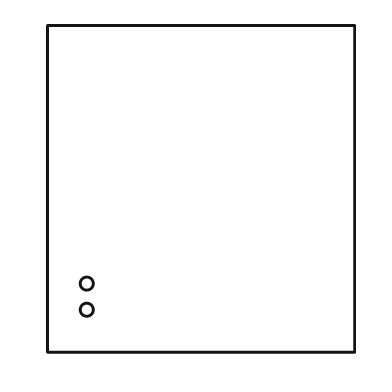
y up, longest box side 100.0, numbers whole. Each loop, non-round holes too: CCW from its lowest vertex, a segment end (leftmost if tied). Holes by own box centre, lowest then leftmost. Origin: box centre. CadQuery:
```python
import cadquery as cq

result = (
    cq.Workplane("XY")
    .moveTo(-47.0, -50.0)
    .lineTo(47.0, -50.0)
    .lineTo(47.0, 50.0)
    .lineTo(-47.0, 50.0)
    .close()
    .moveTo(-35.0, -37.0)
    .circle(2.0)
    .moveTo(-35.0, -29.0)
    .circle(2.0)
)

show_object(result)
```